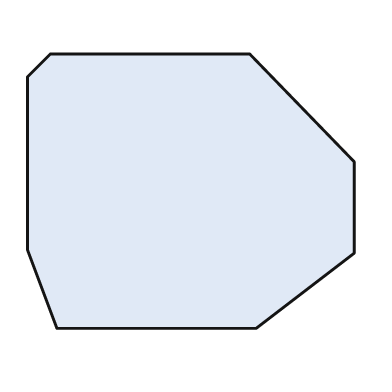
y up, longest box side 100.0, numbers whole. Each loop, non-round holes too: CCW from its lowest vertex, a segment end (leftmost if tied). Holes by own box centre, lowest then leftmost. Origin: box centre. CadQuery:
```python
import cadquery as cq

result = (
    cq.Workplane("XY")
    .moveTo(-41.0, -42.0)
    .lineTo(20.0, -42.0)
    .lineTo(50.0, -19.0)
    .lineTo(50.0, 9.0)
    .lineTo(18.0, 42.0)
    .lineTo(-43.0, 42.0)
    .lineTo(-50.0, 35.0)
    .lineTo(-50.0, -18.0)
    .close()
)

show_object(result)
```